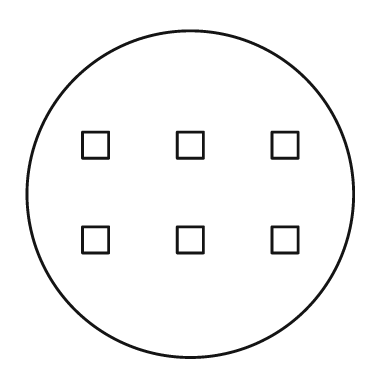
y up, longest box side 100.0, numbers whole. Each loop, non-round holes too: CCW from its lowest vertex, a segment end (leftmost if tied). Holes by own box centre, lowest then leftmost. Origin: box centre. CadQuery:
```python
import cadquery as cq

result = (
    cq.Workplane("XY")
    .moveTo(0.0, 0.0)
    .circle(50.0)
    .moveTo(-33.0, -18.0)
    .lineTo(-25.0, -18.0)
    .lineTo(-25.0, -10.0)
    .lineTo(-33.0, -10.0)
    .close()
    .moveTo(-4.0, -18.0)
    .lineTo(4.0, -18.0)
    .lineTo(4.0, -10.0)
    .lineTo(-4.0, -10.0)
    .close()
    .moveTo(25.0, -18.0)
    .lineTo(33.0, -18.0)
    .lineTo(33.0, -10.0)
    .lineTo(25.0, -10.0)
    .close()
    .moveTo(-33.0, 11.0)
    .lineTo(-25.0, 11.0)
    .lineTo(-25.0, 19.0)
    .lineTo(-33.0, 19.0)
    .close()
    .moveTo(-4.0, 11.0)
    .lineTo(4.0, 11.0)
    .lineTo(4.0, 19.0)
    .lineTo(-4.0, 19.0)
    .close()
    .moveTo(25.0, 11.0)
    .lineTo(33.0, 11.0)
    .lineTo(33.0, 19.0)
    .lineTo(25.0, 19.0)
    .close()
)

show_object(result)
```